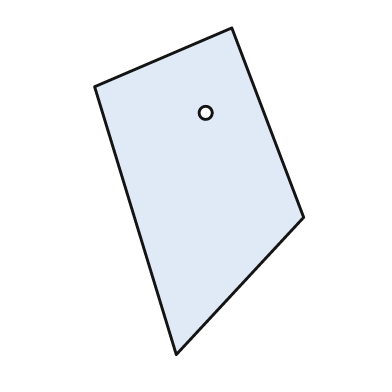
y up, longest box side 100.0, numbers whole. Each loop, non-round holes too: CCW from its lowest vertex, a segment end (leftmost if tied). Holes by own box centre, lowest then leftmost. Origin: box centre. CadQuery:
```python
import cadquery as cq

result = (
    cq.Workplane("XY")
    .moveTo(-7.0, -50.0)
    .lineTo(32.0, -8.0)
    .lineTo(10.0, 50.0)
    .lineTo(-32.0, 32.0)
    .close()
    .moveTo(2.0, 24.0)
    .circle(2.0)
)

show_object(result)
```